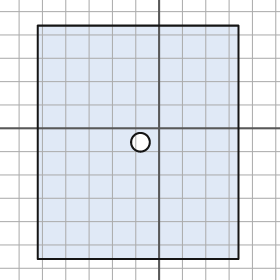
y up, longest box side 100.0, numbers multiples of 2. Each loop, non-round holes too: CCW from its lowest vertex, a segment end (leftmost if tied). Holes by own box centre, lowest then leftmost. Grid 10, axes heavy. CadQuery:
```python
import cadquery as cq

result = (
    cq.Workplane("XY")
    .moveTo(-52.0, -56.0)
    .lineTo(34.0, -56.0)
    .lineTo(34.0, 44.0)
    .lineTo(-52.0, 44.0)
    .close()
    .moveTo(-8.0, -6.0)
    .circle(4.0)
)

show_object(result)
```